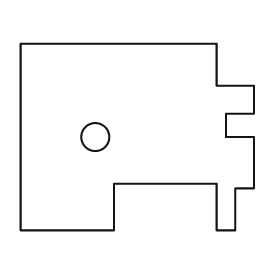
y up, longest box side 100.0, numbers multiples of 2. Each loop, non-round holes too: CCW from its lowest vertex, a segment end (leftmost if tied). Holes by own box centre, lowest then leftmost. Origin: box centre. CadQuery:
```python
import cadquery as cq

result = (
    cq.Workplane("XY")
    .moveTo(-50.0, -40.0)
    .lineTo(-10.0, -40.0)
    .lineTo(-10.0, -20.0)
    .lineTo(34.0, -20.0)
    .lineTo(34.0, -40.0)
    .lineTo(42.0, -40.0)
    .lineTo(42.0, -22.0)
    .lineTo(50.0, -22.0)
    .lineTo(50.0, 0.0)
    .lineTo(38.0, 0.0)
    .lineTo(38.0, 10.0)
    .lineTo(50.0, 10.0)
    .lineTo(50.0, 22.0)
    .lineTo(34.0, 22.0)
    .lineTo(34.0, 40.0)
    .lineTo(-50.0, 40.0)
    .close()
    .moveTo(-18.0, 0.0)
    .circle(6.0)
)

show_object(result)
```